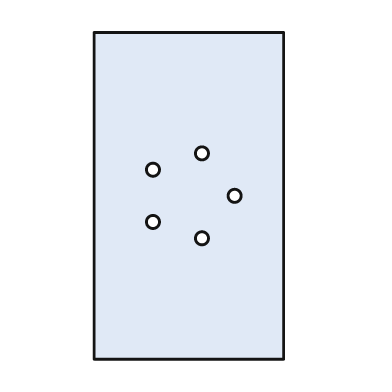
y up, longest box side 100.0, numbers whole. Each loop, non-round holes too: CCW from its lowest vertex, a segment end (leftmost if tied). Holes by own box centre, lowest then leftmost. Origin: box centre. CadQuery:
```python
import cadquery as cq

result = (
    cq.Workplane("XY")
    .moveTo(-29.0, -50.0)
    .lineTo(29.0, -50.0)
    .lineTo(29.0, 50.0)
    .lineTo(-29.0, 50.0)
    .close()
    .moveTo(4.0, -13.0)
    .circle(2.0)
    .moveTo(-11.0, -8.0)
    .circle(2.0)
    .moveTo(14.0, 0.0)
    .circle(2.0)
    .moveTo(-11.0, 8.0)
    .circle(2.0)
    .moveTo(4.0, 13.0)
    .circle(2.0)
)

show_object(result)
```